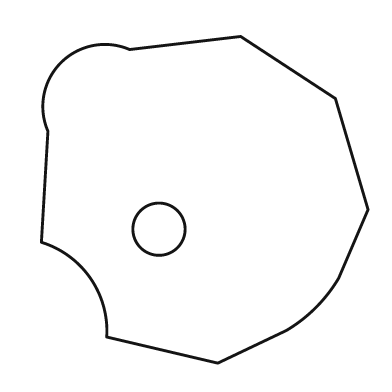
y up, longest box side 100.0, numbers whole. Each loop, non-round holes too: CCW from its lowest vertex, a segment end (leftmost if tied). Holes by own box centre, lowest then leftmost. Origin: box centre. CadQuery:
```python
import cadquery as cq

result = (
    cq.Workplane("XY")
    .moveTo(4.0, -50.0)
    .lineTo(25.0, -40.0)
    .threePointArc((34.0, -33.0), (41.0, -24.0))
    .lineTo(50.0, -3.0)
    .lineTo(40.0, 31.0)
    .lineTo(11.0, 50.0)
    .lineTo(-23.0, 46.0)
    .threePointArc((-44.0, 42.0), (-48.0, 21.0))
    .lineTo(-50.0, -13.0)
    .threePointArc((-35.0, -24.0), (-30.0, -42.0))
    .close()
    .moveTo(-14.0, -9.0)
    .circle(8.0)
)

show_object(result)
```